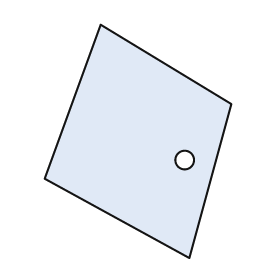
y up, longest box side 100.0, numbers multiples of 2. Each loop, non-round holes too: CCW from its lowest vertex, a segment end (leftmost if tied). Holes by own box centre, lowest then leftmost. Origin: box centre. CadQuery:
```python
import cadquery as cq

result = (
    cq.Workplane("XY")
    .moveTo(22.0, -50.0)
    .lineTo(40.0, 16.0)
    .lineTo(-16.0, 50.0)
    .lineTo(-40.0, -16.0)
    .close()
    .moveTo(20.0, -8.0)
    .circle(4.0)
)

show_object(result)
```